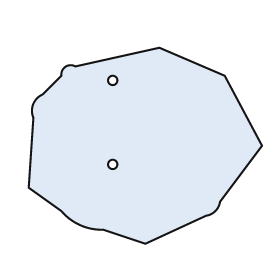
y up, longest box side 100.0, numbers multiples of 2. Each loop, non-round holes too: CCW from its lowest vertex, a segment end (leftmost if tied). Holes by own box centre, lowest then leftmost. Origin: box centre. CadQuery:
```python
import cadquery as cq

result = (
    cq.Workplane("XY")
    .moveTo(0.0, -42.0)
    .lineTo(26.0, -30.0)
    .threePointArc((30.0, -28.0), (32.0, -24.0))
    .lineTo(50.0, 0.0)
    .lineTo(34.0, 30.0)
    .lineTo(6.0, 42.0)
    .lineTo(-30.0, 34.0)
    .threePointArc((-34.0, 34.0), (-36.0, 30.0))
    .lineTo(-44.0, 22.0)
    .threePointArc((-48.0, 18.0), (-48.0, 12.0))
    .lineTo(-50.0, -18.0)
    .lineTo(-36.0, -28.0)
    .threePointArc((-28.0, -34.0), (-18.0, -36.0))
    .close()
    .moveTo(-14.0, -8.0)
    .circle(2.0)
    .moveTo(-14.0, 28.0)
    .circle(2.0)
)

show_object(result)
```